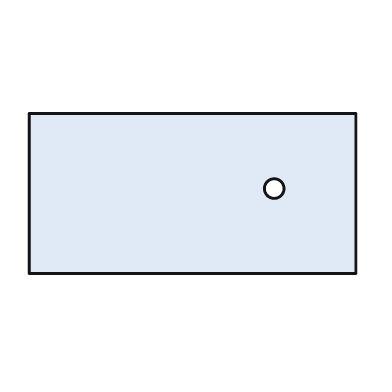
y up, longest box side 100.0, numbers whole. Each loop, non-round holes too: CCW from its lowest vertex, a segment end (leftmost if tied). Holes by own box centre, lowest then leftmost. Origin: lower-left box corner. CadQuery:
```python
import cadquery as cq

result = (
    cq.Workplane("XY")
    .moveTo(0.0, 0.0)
    .lineTo(100.0, 0.0)
    .lineTo(100.0, 49.0)
    .lineTo(0.0, 49.0)
    .close()
    .moveTo(75.0, 26.0)
    .circle(3.0)
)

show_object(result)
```